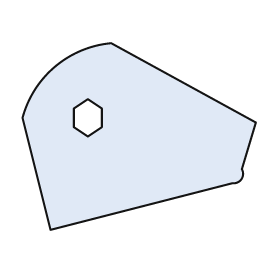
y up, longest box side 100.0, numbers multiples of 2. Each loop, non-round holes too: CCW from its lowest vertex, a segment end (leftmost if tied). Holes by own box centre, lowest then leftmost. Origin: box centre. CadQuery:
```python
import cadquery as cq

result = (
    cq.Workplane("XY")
    .moveTo(-38.0, -40.0)
    .lineTo(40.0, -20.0)
    .threePointArc((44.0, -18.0), (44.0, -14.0))
    .lineTo(50.0, 6.0)
    .lineTo(-12.0, 40.0)
    .threePointArc((-36.0, 30.0), (-50.0, 8.0))
    .close()
    .moveTo(-22.0, 0.0)
    .lineTo(-16.0, 4.0)
    .lineTo(-16.0, 12.0)
    .lineTo(-22.0, 16.0)
    .lineTo(-28.0, 12.0)
    .lineTo(-28.0, 4.0)
    .close()
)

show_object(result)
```